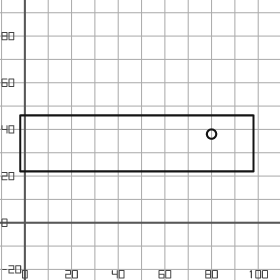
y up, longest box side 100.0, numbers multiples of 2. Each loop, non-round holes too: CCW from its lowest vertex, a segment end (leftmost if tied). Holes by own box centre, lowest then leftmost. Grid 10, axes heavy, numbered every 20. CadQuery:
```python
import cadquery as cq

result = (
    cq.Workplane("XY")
    .moveTo(-2.0, 22.0)
    .lineTo(98.0, 22.0)
    .lineTo(98.0, 46.0)
    .lineTo(-2.0, 46.0)
    .close()
    .moveTo(80.0, 38.0)
    .circle(2.0)
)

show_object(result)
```